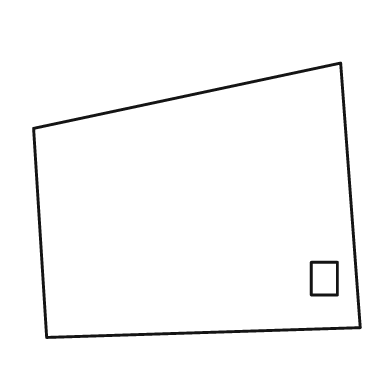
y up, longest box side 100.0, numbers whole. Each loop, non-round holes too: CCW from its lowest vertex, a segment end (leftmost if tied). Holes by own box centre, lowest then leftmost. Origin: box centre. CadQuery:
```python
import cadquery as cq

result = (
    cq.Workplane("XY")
    .moveTo(-46.0, -42.0)
    .lineTo(50.0, -39.0)
    .lineTo(44.0, 42.0)
    .lineTo(-50.0, 22.0)
    .close()
    .moveTo(35.0, -29.0)
    .lineTo(43.0, -29.0)
    .lineTo(43.0, -19.0)
    .lineTo(35.0, -19.0)
    .close()
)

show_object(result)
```